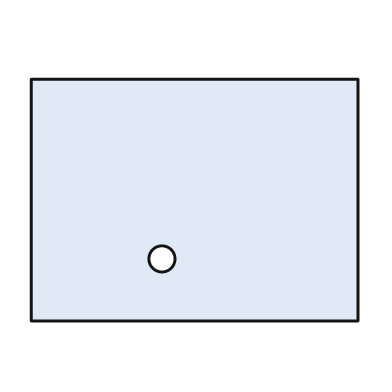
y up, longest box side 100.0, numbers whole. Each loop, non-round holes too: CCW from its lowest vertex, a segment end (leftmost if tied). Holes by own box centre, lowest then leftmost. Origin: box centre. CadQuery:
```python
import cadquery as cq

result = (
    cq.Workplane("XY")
    .moveTo(-50.0, -37.0)
    .lineTo(50.0, -37.0)
    .lineTo(50.0, 37.0)
    .lineTo(-50.0, 37.0)
    .close()
    .moveTo(-10.0, -18.0)
    .circle(4.0)
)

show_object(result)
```